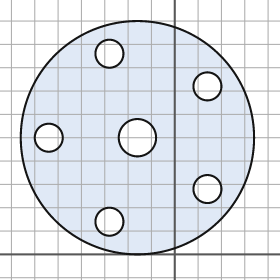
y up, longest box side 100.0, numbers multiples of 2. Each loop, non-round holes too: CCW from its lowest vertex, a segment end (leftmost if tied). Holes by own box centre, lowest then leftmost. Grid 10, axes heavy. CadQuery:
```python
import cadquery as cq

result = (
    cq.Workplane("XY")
    .moveTo(-16.0, 50.0)
    .circle(50.0)
    .moveTo(-28.0, 14.0)
    .circle(6.0)
    .moveTo(14.0, 28.0)
    .circle(6.0)
    .moveTo(-54.0, 50.0)
    .circle(6.0)
    .moveTo(-16.0, 50.0)
    .circle(8.0)
    .moveTo(14.0, 72.0)
    .circle(6.0)
    .moveTo(-28.0, 86.0)
    .circle(6.0)
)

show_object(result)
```